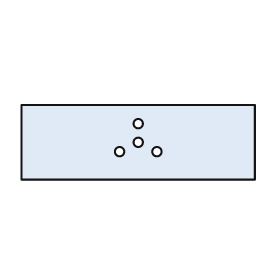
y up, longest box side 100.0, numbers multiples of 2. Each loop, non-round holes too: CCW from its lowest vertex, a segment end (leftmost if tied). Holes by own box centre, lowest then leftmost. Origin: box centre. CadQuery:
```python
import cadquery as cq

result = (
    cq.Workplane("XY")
    .moveTo(-50.0, -16.0)
    .lineTo(50.0, -16.0)
    .lineTo(50.0, 16.0)
    .lineTo(-50.0, 16.0)
    .close()
    .moveTo(-8.0, -4.0)
    .circle(2.0)
    .moveTo(8.0, -4.0)
    .circle(2.0)
    .moveTo(0.0, 0.0)
    .circle(2.0)
    .moveTo(0.0, 8.0)
    .circle(2.0)
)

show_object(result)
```